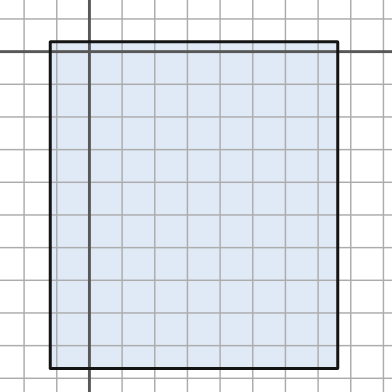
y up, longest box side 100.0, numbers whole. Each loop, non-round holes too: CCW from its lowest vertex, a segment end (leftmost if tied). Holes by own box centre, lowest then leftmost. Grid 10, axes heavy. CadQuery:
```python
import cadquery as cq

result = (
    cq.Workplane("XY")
    .moveTo(-12.0, -97.0)
    .lineTo(76.0, -97.0)
    .lineTo(76.0, 3.0)
    .lineTo(-12.0, 3.0)
    .close()
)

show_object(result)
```